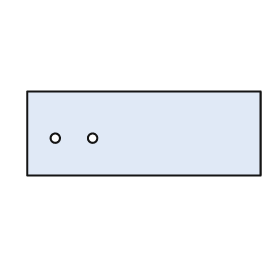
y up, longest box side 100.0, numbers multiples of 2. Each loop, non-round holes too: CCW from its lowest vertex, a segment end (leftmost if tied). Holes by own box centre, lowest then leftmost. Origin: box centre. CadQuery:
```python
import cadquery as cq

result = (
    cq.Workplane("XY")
    .moveTo(-50.0, -18.0)
    .lineTo(50.0, -18.0)
    .lineTo(50.0, 18.0)
    .lineTo(-50.0, 18.0)
    .close()
    .moveTo(-38.0, -2.0)
    .circle(2.0)
    .moveTo(-22.0, -2.0)
    .circle(2.0)
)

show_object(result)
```